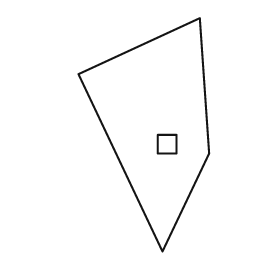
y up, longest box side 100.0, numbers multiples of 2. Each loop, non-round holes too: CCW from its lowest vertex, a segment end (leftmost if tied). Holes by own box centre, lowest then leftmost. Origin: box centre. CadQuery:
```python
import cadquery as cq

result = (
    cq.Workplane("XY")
    .moveTo(8.0, -50.0)
    .lineTo(28.0, -8.0)
    .lineTo(24.0, 50.0)
    .lineTo(-28.0, 26.0)
    .close()
    .moveTo(6.0, -8.0)
    .lineTo(14.0, -8.0)
    .lineTo(14.0, 0.0)
    .lineTo(6.0, 0.0)
    .close()
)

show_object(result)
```